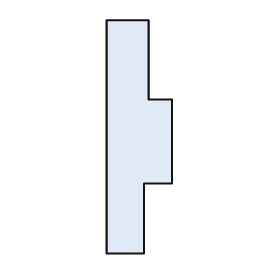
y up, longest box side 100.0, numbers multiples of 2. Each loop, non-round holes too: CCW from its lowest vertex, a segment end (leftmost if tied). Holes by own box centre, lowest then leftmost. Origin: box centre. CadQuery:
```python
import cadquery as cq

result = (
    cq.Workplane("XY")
    .moveTo(-14.0, -50.0)
    .lineTo(2.0, -50.0)
    .lineTo(2.0, -20.0)
    .lineTo(14.0, -20.0)
    .lineTo(14.0, 16.0)
    .lineTo(4.0, 16.0)
    .lineTo(4.0, 50.0)
    .lineTo(-14.0, 50.0)
    .close()
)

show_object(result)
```